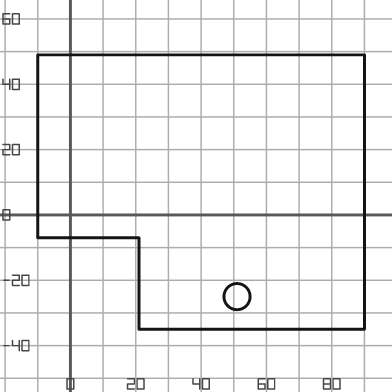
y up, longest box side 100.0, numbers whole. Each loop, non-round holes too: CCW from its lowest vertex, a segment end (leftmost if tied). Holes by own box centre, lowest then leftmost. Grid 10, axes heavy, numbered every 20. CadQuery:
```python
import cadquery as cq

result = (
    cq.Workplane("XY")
    .moveTo(21.0, -35.0)
    .lineTo(90.0, -35.0)
    .lineTo(90.0, 49.0)
    .lineTo(-10.0, 49.0)
    .lineTo(-10.0, -7.0)
    .lineTo(21.0, -7.0)
    .close()
    .moveTo(51.0, -25.0)
    .circle(4.0)
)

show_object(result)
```